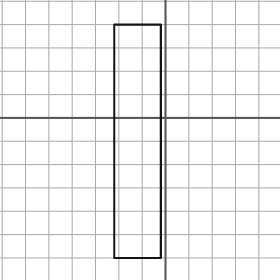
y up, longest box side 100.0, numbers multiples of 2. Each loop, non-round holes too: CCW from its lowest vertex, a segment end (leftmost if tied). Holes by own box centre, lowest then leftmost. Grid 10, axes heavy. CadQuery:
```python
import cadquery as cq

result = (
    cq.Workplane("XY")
    .moveTo(-22.0, -60.0)
    .lineTo(-2.0, -60.0)
    .lineTo(-2.0, 40.0)
    .lineTo(-22.0, 40.0)
    .close()
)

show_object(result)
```